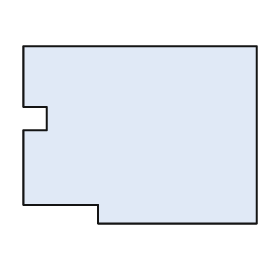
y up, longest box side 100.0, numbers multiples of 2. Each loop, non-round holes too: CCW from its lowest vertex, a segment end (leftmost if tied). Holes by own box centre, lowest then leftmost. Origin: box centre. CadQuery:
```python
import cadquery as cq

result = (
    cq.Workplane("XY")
    .moveTo(-18.0, -38.0)
    .lineTo(50.0, -38.0)
    .lineTo(50.0, 38.0)
    .lineTo(-50.0, 38.0)
    .lineTo(-50.0, 12.0)
    .lineTo(-40.0, 12.0)
    .lineTo(-40.0, 2.0)
    .lineTo(-50.0, 2.0)
    .lineTo(-50.0, -30.0)
    .lineTo(-18.0, -30.0)
    .close()
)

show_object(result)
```